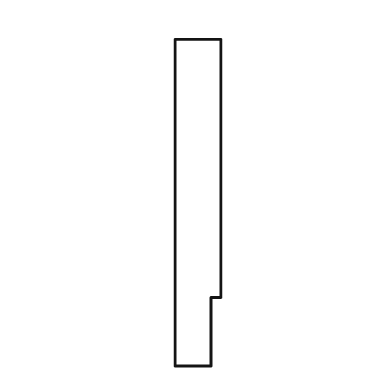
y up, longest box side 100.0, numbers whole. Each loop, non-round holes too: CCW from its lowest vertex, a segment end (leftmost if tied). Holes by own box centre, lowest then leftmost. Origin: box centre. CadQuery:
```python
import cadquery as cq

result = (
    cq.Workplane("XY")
    .moveTo(-7.0, -50.0)
    .lineTo(4.0, -50.0)
    .lineTo(4.0, -29.0)
    .lineTo(7.0, -29.0)
    .lineTo(7.0, 50.0)
    .lineTo(-7.0, 50.0)
    .close()
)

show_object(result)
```